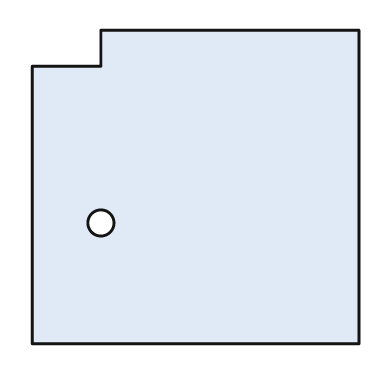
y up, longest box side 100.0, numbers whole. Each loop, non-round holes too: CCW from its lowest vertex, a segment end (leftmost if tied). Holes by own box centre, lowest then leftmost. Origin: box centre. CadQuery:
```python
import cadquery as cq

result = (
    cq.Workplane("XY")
    .moveTo(-50.0, -48.0)
    .lineTo(50.0, -48.0)
    .lineTo(50.0, 48.0)
    .lineTo(-29.0, 48.0)
    .lineTo(-29.0, 37.0)
    .lineTo(-50.0, 37.0)
    .close()
    .moveTo(-29.0, -11.0)
    .circle(4.0)
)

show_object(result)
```